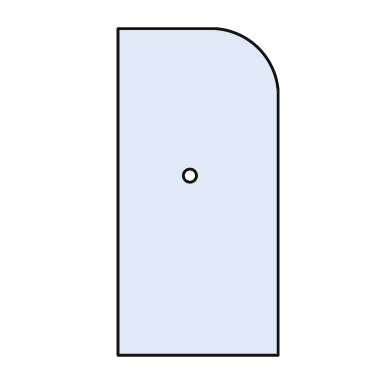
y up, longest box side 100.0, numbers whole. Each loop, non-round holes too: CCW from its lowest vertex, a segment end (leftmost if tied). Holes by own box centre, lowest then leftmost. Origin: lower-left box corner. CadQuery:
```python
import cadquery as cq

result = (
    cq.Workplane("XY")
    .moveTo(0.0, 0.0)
    .lineTo(49.0, 0.0)
    .lineTo(49.0, 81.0)
    .threePointArc((43.0, 94.0), (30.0, 100.0))
    .lineTo(0.0, 100.0)
    .close()
    .moveTo(22.0, 55.0)
    .circle(2.0)
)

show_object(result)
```